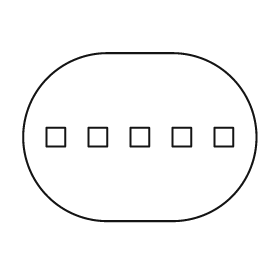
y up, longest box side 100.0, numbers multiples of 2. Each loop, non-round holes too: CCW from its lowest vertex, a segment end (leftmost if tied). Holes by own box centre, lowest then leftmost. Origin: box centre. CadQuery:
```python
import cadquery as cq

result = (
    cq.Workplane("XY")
    .moveTo(-14.0, -36.0)
    .lineTo(14.0, -36.0)
    .threePointArc((50.0, 0.0), (14.0, 36.0))
    .lineTo(-14.0, 36.0)
    .threePointArc((-50.0, 0.0), (-14.0, -36.0))
    .close()
    .moveTo(-40.0, -4.0)
    .lineTo(-32.0, -4.0)
    .lineTo(-32.0, 4.0)
    .lineTo(-40.0, 4.0)
    .close()
    .moveTo(-22.0, -4.0)
    .lineTo(-14.0, -4.0)
    .lineTo(-14.0, 4.0)
    .lineTo(-22.0, 4.0)
    .close()
    .moveTo(-4.0, -4.0)
    .lineTo(4.0, -4.0)
    .lineTo(4.0, 4.0)
    .lineTo(-4.0, 4.0)
    .close()
    .moveTo(14.0, -4.0)
    .lineTo(22.0, -4.0)
    .lineTo(22.0, 4.0)
    .lineTo(14.0, 4.0)
    .close()
    .moveTo(32.0, -4.0)
    .lineTo(40.0, -4.0)
    .lineTo(40.0, 4.0)
    .lineTo(32.0, 4.0)
    .close()
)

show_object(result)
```